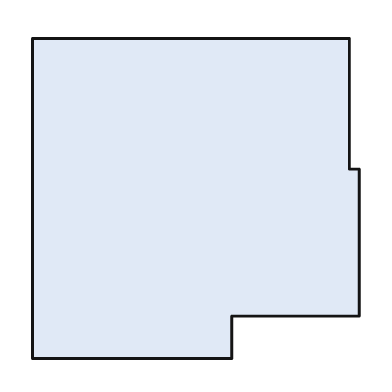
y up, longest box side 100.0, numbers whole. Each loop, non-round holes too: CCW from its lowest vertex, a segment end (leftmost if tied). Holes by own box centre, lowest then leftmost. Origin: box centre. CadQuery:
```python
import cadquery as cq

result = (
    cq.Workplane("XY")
    .moveTo(-50.0, -49.0)
    .lineTo(11.0, -49.0)
    .lineTo(11.0, -36.0)
    .lineTo(50.0, -36.0)
    .lineTo(50.0, 9.0)
    .lineTo(47.0, 9.0)
    .lineTo(47.0, 49.0)
    .lineTo(-50.0, 49.0)
    .close()
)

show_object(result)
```